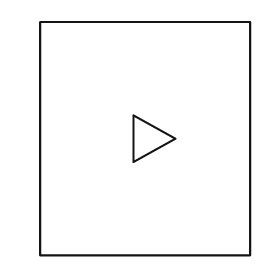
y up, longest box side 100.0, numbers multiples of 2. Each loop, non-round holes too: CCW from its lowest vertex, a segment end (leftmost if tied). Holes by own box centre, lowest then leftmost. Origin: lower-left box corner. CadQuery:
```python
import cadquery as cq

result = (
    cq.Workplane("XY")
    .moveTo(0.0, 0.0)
    .lineTo(90.0, 0.0)
    .lineTo(90.0, 100.0)
    .lineTo(0.0, 100.0)
    .close()
    .moveTo(40.0, 40.0)
    .lineTo(58.0, 50.0)
    .lineTo(40.0, 60.0)
    .close()
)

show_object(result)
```